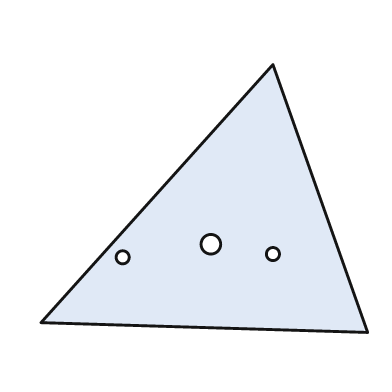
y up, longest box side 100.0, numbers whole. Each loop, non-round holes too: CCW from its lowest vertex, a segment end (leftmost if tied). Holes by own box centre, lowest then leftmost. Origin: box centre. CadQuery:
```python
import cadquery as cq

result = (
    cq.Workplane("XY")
    .moveTo(50.0, -41.0)
    .lineTo(21.0, 41.0)
    .lineTo(-50.0, -38.0)
    .close()
    .moveTo(-25.0, -18.0)
    .circle(2.0)
    .moveTo(21.0, -17.0)
    .circle(2.0)
    .moveTo(2.0, -14.0)
    .circle(3.0)
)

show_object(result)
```